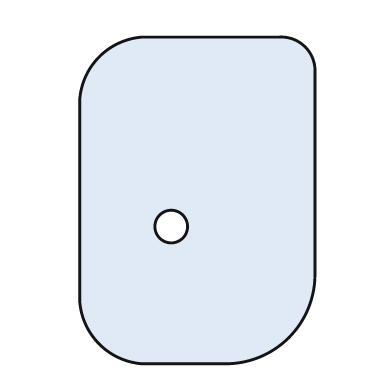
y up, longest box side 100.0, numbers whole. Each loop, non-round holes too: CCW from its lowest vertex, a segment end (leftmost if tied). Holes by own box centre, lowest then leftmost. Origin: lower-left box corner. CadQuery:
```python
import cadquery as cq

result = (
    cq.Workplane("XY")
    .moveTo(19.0, 0.0)
    .lineTo(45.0, 0.0)
    .threePointArc((64.0, 8.0), (72.0, 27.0))
    .lineTo(72.0, 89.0)
    .threePointArc((69.0, 97.0), (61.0, 100.0))
    .lineTo(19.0, 100.0)
    .threePointArc((6.0, 94.0), (0.0, 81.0))
    .lineTo(0.0, 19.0)
    .threePointArc((6.0, 6.0), (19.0, 0.0))
    .close()
    .moveTo(28.0, 42.0)
    .circle(5.0)
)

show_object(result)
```